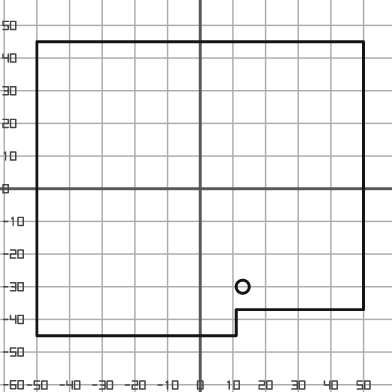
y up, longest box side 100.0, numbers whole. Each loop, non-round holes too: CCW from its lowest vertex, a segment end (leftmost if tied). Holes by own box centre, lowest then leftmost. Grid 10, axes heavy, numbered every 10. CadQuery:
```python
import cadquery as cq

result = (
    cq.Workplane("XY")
    .moveTo(-50.0, -45.0)
    .lineTo(11.0, -45.0)
    .lineTo(11.0, -37.0)
    .lineTo(50.0, -37.0)
    .lineTo(50.0, 45.0)
    .lineTo(-50.0, 45.0)
    .close()
    .moveTo(13.0, -30.0)
    .circle(2.0)
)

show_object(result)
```